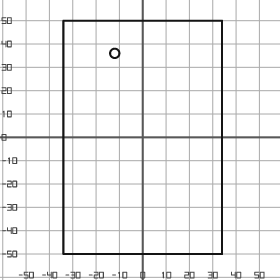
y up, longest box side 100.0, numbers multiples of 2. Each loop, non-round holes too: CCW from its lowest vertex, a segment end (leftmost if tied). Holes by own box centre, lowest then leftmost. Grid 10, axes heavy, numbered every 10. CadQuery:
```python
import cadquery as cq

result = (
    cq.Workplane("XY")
    .moveTo(-34.0, -50.0)
    .lineTo(34.0, -50.0)
    .lineTo(34.0, 50.0)
    .lineTo(-34.0, 50.0)
    .close()
    .moveTo(-12.0, 36.0)
    .circle(2.0)
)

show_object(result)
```